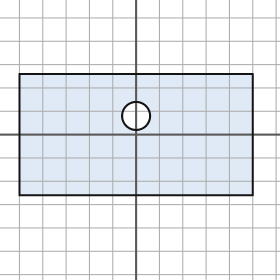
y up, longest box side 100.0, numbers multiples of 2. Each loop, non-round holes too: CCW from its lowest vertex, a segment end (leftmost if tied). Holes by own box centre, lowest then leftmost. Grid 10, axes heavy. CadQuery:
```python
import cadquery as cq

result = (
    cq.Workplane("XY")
    .moveTo(-50.0, -26.0)
    .lineTo(50.0, -26.0)
    .lineTo(50.0, 26.0)
    .lineTo(-50.0, 26.0)
    .close()
    .moveTo(0.0, 8.0)
    .circle(6.0)
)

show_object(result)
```